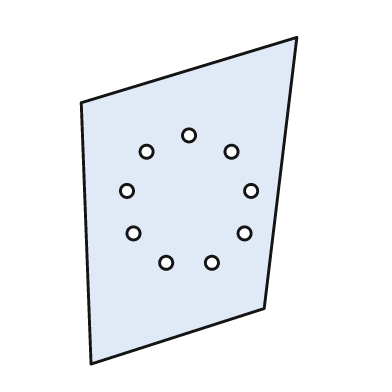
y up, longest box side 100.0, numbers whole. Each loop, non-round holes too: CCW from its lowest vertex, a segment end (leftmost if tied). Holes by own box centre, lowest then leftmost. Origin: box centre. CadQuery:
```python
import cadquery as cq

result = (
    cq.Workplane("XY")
    .moveTo(-30.0, -50.0)
    .lineTo(23.0, -33.0)
    .lineTo(33.0, 50.0)
    .lineTo(-33.0, 30.0)
    .close()
    .moveTo(-7.0, -19.0)
    .circle(2.0)
    .moveTo(7.0, -19.0)
    .circle(2.0)
    .moveTo(-17.0, -10.0)
    .circle(2.0)
    .moveTo(17.0, -10.0)
    .circle(2.0)
    .moveTo(-19.0, 3.0)
    .circle(2.0)
    .moveTo(19.0, 3.0)
    .circle(2.0)
    .moveTo(-13.0, 15.0)
    .circle(2.0)
    .moveTo(13.0, 15.0)
    .circle(2.0)
    .moveTo(0.0, 20.0)
    .circle(2.0)
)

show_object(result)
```